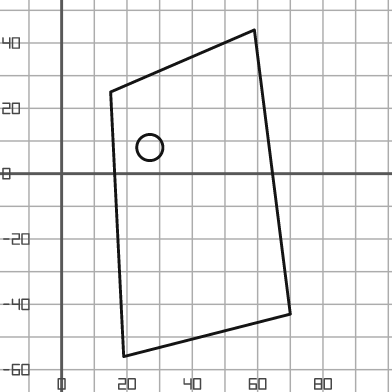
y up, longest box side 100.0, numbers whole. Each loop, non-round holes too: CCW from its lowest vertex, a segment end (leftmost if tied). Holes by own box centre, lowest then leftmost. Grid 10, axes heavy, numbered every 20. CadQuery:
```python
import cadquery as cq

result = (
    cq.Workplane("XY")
    .moveTo(19.0, -56.0)
    .lineTo(70.0, -43.0)
    .lineTo(59.0, 44.0)
    .lineTo(15.0, 25.0)
    .close()
    .moveTo(27.0, 8.0)
    .circle(4.0)
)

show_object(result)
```